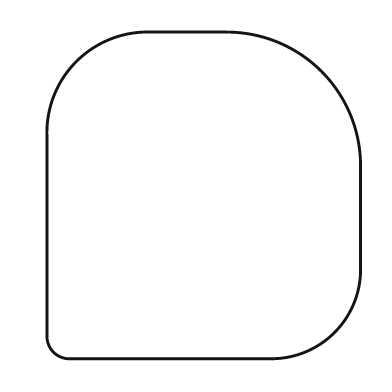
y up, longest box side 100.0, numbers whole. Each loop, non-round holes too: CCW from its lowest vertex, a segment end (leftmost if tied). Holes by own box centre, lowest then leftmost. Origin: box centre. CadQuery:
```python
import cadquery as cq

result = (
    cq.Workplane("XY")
    .moveTo(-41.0, -50.0)
    .lineTo(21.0, -50.0)
    .threePointArc((40.0, -42.0), (48.0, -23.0))
    .lineTo(48.0, 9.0)
    .threePointArc((36.0, 38.0), (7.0, 50.0))
    .lineTo(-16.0, 50.0)
    .threePointArc((-39.0, 41.0), (-48.0, 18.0))
    .lineTo(-48.0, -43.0)
    .threePointArc((-46.0, -48.0), (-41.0, -50.0))
    .close()
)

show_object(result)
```